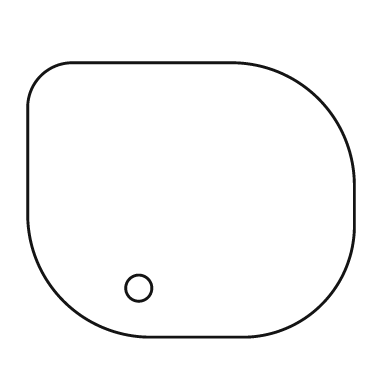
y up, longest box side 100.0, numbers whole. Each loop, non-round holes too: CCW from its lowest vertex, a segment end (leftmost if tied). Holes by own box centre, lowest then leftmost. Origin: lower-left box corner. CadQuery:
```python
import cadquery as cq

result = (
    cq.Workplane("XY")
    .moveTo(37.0, 0.0)
    .lineTo(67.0, 0.0)
    .threePointArc((90.0, 10.0), (100.0, 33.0))
    .lineTo(100.0, 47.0)
    .threePointArc((89.0, 73.0), (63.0, 84.0))
    .lineTo(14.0, 84.0)
    .threePointArc((4.0, 80.0), (0.0, 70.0))
    .lineTo(0.0, 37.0)
    .threePointArc((11.0, 11.0), (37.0, 0.0))
    .close()
    .moveTo(34.0, 15.0)
    .circle(4.0)
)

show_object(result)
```